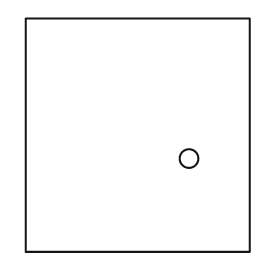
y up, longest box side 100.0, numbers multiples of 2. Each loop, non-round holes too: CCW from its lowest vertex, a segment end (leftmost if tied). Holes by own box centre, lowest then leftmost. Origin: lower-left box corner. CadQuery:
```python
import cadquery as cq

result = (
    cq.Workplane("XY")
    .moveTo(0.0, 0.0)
    .lineTo(96.0, 0.0)
    .lineTo(96.0, 100.0)
    .lineTo(0.0, 100.0)
    .close()
    .moveTo(70.0, 40.0)
    .circle(4.0)
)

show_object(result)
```